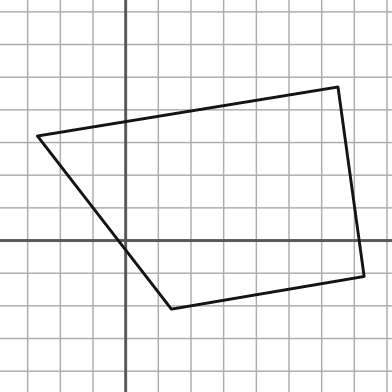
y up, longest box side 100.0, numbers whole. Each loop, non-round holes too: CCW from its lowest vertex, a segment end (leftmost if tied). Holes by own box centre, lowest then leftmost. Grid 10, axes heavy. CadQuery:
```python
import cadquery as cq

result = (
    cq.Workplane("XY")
    .moveTo(14.0, -21.0)
    .lineTo(73.0, -11.0)
    .lineTo(65.0, 47.0)
    .lineTo(-27.0, 32.0)
    .close()
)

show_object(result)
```